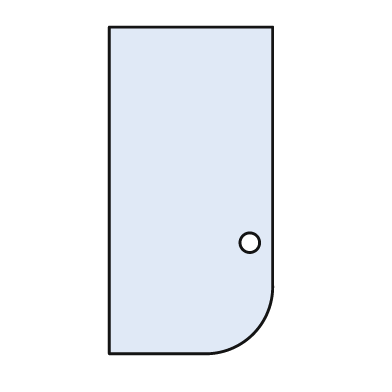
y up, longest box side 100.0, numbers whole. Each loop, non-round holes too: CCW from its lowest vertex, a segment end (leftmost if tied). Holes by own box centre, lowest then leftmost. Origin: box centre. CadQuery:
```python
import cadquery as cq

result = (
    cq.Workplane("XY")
    .moveTo(-25.0, -50.0)
    .lineTo(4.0, -50.0)
    .threePointArc((19.0, -44.0), (25.0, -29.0))
    .lineTo(25.0, 50.0)
    .lineTo(-25.0, 50.0)
    .close()
    .moveTo(18.0, -16.0)
    .circle(3.0)
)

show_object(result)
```